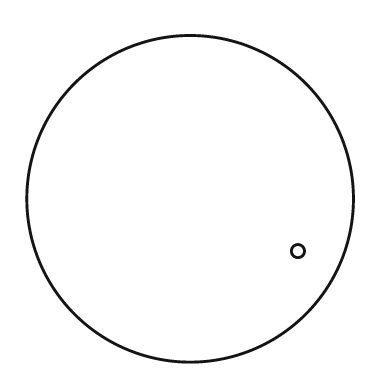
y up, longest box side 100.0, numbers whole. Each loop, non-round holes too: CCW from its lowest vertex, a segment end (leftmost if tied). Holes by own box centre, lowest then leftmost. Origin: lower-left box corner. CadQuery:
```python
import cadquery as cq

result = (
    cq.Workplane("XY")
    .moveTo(50.0, 50.0)
    .circle(50.0)
    .moveTo(83.0, 34.0)
    .circle(2.0)
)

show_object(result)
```